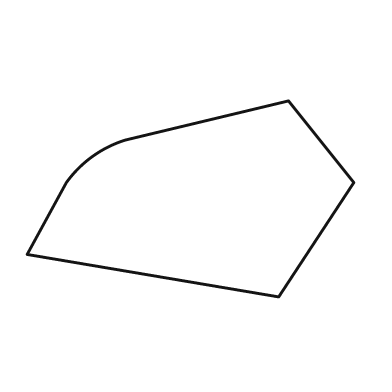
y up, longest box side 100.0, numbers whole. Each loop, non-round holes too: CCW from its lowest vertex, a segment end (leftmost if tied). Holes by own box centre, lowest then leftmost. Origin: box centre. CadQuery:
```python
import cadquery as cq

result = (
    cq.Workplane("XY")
    .moveTo(27.0, -30.0)
    .lineTo(50.0, 5.0)
    .lineTo(30.0, 30.0)
    .lineTo(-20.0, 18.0)
    .threePointArc((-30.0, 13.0), (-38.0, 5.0))
    .lineTo(-50.0, -17.0)
    .close()
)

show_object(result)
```